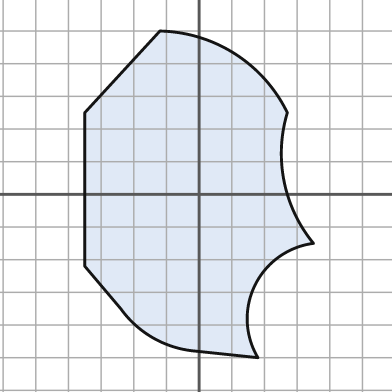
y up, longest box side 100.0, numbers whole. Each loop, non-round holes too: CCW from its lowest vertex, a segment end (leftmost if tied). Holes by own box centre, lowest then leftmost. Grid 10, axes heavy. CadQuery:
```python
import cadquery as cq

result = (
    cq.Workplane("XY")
    .moveTo(18.0, -50.0)
    .threePointArc((17.0, -28.0), (35.0, -15.0))
    .threePointArc((26.0, 4.0), (27.0, 25.0))
    .threePointArc((11.0, 43.0), (-12.0, 50.0))
    .lineTo(-35.0, 25.0)
    .lineTo(-35.0, -22.0)
    .lineTo(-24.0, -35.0)
    .threePointArc((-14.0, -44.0), (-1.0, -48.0))
    .close()
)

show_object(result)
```